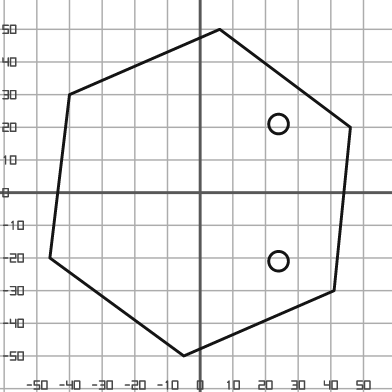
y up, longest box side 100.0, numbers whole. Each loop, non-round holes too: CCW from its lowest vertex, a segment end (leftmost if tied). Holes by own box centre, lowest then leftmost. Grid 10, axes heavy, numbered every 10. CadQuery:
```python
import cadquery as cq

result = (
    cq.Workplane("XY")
    .moveTo(-5.0, -50.0)
    .lineTo(41.0, -30.0)
    .lineTo(46.0, 20.0)
    .lineTo(6.0, 50.0)
    .lineTo(-40.0, 30.0)
    .lineTo(-46.0, -20.0)
    .close()
    .moveTo(24.0, -21.0)
    .circle(3.0)
    .moveTo(24.0, 21.0)
    .circle(3.0)
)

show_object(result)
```